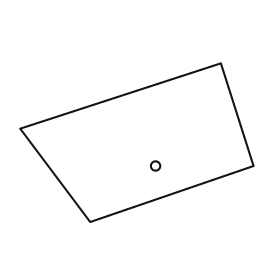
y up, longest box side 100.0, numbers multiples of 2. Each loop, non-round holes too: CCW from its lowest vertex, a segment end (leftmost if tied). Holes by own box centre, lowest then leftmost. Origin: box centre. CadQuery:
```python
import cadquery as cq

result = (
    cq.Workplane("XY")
    .moveTo(-20.0, -34.0)
    .lineTo(50.0, -10.0)
    .lineTo(36.0, 34.0)
    .lineTo(-50.0, 6.0)
    .close()
    .moveTo(8.0, -10.0)
    .circle(2.0)
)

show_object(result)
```